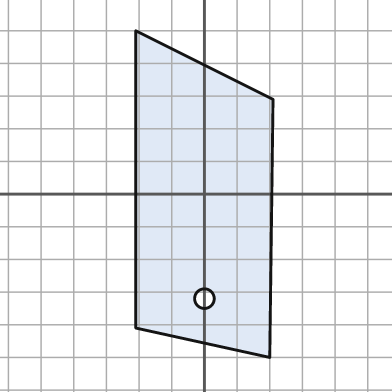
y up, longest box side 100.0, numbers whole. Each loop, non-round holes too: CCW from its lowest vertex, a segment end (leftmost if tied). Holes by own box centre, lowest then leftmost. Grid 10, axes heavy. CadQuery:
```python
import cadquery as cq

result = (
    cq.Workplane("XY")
    .moveTo(20.0, -50.0)
    .lineTo(21.0, 29.0)
    .lineTo(-21.0, 50.0)
    .lineTo(-21.0, -41.0)
    .close()
    .moveTo(0.0, -32.0)
    .circle(3.0)
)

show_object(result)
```